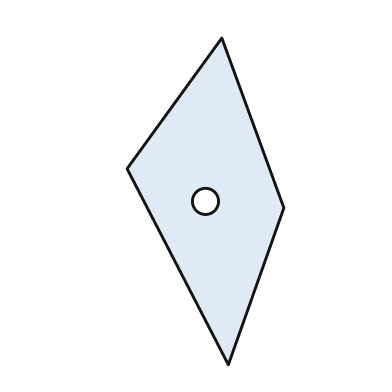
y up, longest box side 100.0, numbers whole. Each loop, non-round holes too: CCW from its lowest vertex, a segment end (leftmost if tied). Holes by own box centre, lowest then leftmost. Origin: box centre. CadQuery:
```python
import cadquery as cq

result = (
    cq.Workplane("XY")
    .moveTo(7.0, -50.0)
    .lineTo(24.0, -2.0)
    .lineTo(5.0, 50.0)
    .lineTo(-24.0, 10.0)
    .close()
    .moveTo(0.0, 0.0)
    .circle(4.0)
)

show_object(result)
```